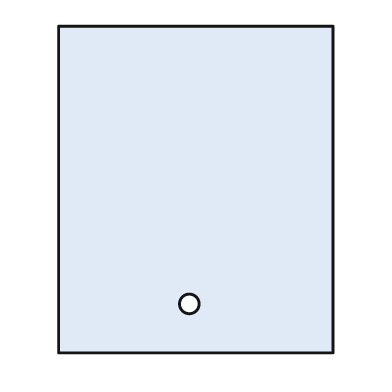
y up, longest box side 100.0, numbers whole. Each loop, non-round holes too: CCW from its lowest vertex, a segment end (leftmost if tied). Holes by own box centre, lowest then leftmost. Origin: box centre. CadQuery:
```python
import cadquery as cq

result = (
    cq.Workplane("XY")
    .moveTo(-42.0, -50.0)
    .lineTo(42.0, -50.0)
    .lineTo(42.0, 50.0)
    .lineTo(-42.0, 50.0)
    .close()
    .moveTo(-2.0, -35.0)
    .circle(3.0)
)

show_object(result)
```